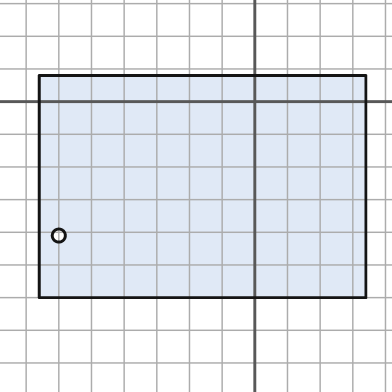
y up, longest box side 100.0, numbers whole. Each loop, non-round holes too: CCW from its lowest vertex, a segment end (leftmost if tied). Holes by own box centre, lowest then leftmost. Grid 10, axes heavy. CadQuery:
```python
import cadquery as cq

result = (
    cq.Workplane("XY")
    .moveTo(-66.0, -60.0)
    .lineTo(34.0, -60.0)
    .lineTo(34.0, 8.0)
    .lineTo(-66.0, 8.0)
    .close()
    .moveTo(-60.0, -41.0)
    .circle(2.0)
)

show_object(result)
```